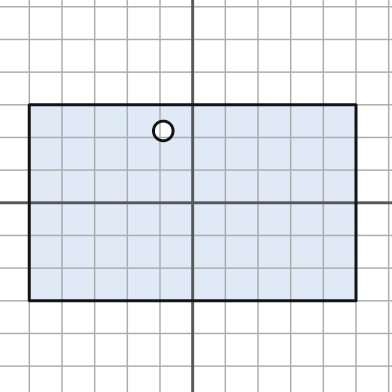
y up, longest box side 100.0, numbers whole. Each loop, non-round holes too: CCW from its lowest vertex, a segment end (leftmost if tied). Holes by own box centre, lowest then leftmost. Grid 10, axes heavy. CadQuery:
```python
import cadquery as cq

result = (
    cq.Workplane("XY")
    .moveTo(-50.0, -30.0)
    .lineTo(50.0, -30.0)
    .lineTo(50.0, 30.0)
    .lineTo(-50.0, 30.0)
    .close()
    .moveTo(-9.0, 22.0)
    .circle(3.0)
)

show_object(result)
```